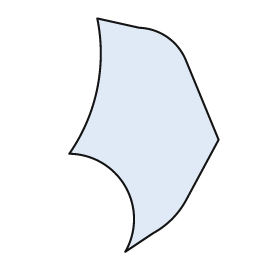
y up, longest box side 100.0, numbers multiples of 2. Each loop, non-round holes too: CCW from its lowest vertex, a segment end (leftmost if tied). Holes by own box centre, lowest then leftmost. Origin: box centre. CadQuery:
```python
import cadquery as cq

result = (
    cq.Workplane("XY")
    .moveTo(-8.0, -50.0)
    .lineTo(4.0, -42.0)
    .threePointArc((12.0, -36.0), (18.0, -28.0))
    .lineTo(32.0, -2.0)
    .lineTo(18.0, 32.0)
    .threePointArc((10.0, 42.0), (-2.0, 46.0))
    .lineTo(-20.0, 50.0)
    .threePointArc((-20.0, 20.0), (-32.0, -8.0))
    .threePointArc((-8.0, -22.0), (-8.0, -50.0))
    .close()
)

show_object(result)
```